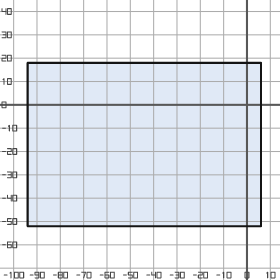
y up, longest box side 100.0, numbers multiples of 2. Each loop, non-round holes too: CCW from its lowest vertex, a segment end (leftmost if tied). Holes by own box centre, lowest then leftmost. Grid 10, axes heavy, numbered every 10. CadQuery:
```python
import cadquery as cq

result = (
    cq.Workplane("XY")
    .moveTo(-94.0, -52.0)
    .lineTo(6.0, -52.0)
    .lineTo(6.0, 18.0)
    .lineTo(-94.0, 18.0)
    .close()
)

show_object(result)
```